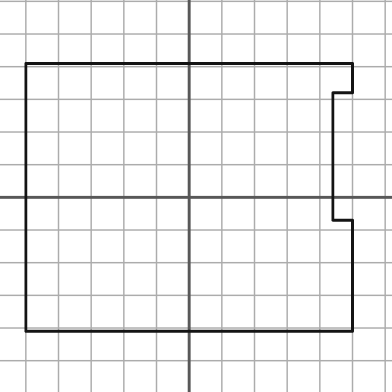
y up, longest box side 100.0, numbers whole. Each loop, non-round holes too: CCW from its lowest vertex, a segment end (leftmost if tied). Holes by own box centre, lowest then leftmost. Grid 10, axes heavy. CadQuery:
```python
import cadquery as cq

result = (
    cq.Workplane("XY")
    .moveTo(-50.0, -41.0)
    .lineTo(50.0, -41.0)
    .lineTo(50.0, -7.0)
    .lineTo(44.0, -7.0)
    .lineTo(44.0, 32.0)
    .lineTo(50.0, 32.0)
    .lineTo(50.0, 41.0)
    .lineTo(-50.0, 41.0)
    .close()
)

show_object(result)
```